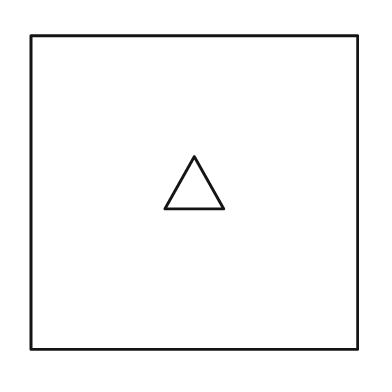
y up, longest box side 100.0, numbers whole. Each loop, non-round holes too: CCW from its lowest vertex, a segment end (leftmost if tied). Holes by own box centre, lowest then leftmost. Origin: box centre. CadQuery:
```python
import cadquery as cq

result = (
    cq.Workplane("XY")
    .moveTo(-50.0, -48.0)
    .lineTo(50.0, -48.0)
    .lineTo(50.0, 48.0)
    .lineTo(-50.0, 48.0)
    .close()
    .moveTo(-9.0, -5.0)
    .lineTo(9.0, -5.0)
    .lineTo(0.0, 11.0)
    .close()
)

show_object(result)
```